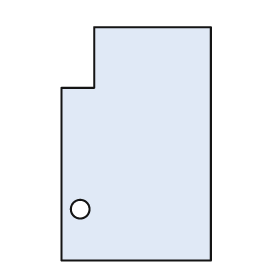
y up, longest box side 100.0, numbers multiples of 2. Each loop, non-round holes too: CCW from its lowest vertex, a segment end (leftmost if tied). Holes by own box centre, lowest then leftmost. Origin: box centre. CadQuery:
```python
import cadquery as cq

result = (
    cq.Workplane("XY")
    .moveTo(-32.0, -50.0)
    .lineTo(32.0, -50.0)
    .lineTo(32.0, 50.0)
    .lineTo(-18.0, 50.0)
    .lineTo(-18.0, 24.0)
    .lineTo(-32.0, 24.0)
    .close()
    .moveTo(-24.0, -28.0)
    .circle(4.0)
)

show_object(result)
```